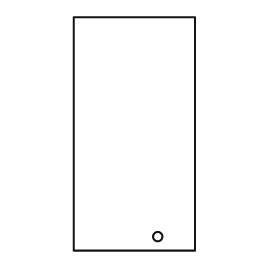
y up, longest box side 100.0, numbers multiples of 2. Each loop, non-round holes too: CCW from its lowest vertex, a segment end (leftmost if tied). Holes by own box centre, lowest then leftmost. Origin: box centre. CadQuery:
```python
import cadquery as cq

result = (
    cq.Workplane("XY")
    .moveTo(-26.0, -50.0)
    .lineTo(26.0, -50.0)
    .lineTo(26.0, 50.0)
    .lineTo(-26.0, 50.0)
    .close()
    .moveTo(10.0, -44.0)
    .circle(2.0)
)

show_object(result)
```